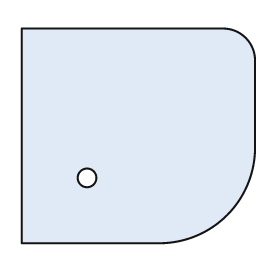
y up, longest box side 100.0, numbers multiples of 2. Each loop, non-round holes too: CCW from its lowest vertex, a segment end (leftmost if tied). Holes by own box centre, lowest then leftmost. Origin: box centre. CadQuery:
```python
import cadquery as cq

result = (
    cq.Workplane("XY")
    .moveTo(-50.0, -46.0)
    .lineTo(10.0, -46.0)
    .threePointArc((38.0, -34.0), (50.0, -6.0))
    .lineTo(50.0, 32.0)
    .threePointArc((46.0, 42.0), (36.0, 46.0))
    .lineTo(-50.0, 46.0)
    .close()
    .moveTo(-22.0, -18.0)
    .circle(4.0)
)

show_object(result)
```